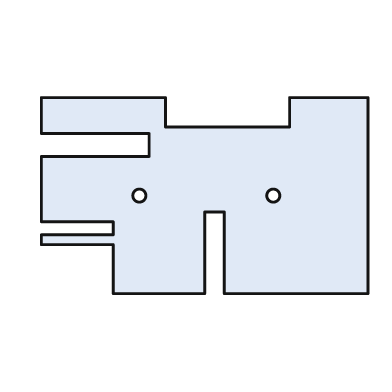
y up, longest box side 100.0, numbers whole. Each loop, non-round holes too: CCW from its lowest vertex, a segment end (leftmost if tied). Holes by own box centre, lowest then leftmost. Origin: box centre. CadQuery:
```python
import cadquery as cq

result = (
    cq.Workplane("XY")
    .moveTo(-28.0, -30.0)
    .lineTo(0.0, -30.0)
    .lineTo(0.0, -5.0)
    .lineTo(6.0, -5.0)
    .lineTo(6.0, -30.0)
    .lineTo(50.0, -30.0)
    .lineTo(50.0, 30.0)
    .lineTo(26.0, 30.0)
    .lineTo(26.0, 21.0)
    .lineTo(-12.0, 21.0)
    .lineTo(-12.0, 30.0)
    .lineTo(-50.0, 30.0)
    .lineTo(-50.0, 19.0)
    .lineTo(-17.0, 19.0)
    .lineTo(-17.0, 12.0)
    .lineTo(-50.0, 12.0)
    .lineTo(-50.0, -8.0)
    .lineTo(-28.0, -8.0)
    .lineTo(-28.0, -12.0)
    .lineTo(-50.0, -12.0)
    .lineTo(-50.0, -15.0)
    .lineTo(-28.0, -15.0)
    .close()
    .moveTo(-20.0, 0.0)
    .circle(2.0)
    .moveTo(21.0, 0.0)
    .circle(2.0)
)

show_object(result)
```